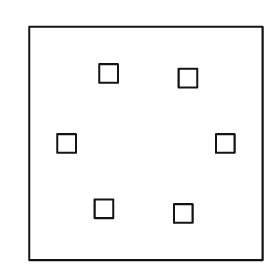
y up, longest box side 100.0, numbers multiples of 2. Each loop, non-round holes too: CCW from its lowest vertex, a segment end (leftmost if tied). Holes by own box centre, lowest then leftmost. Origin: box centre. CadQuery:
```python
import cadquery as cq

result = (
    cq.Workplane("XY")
    .moveTo(-50.0, -50.0)
    .lineTo(50.0, -50.0)
    .lineTo(50.0, 50.0)
    .lineTo(-50.0, 50.0)
    .close()
    .moveTo(12.0, -34.0)
    .lineTo(20.0, -34.0)
    .lineTo(20.0, -26.0)
    .lineTo(12.0, -26.0)
    .close()
    .moveTo(-22.0, -32.0)
    .lineTo(-14.0, -32.0)
    .lineTo(-14.0, -24.0)
    .lineTo(-22.0, -24.0)
    .close()
    .moveTo(-38.0, -4.0)
    .lineTo(-30.0, -4.0)
    .lineTo(-30.0, 4.0)
    .lineTo(-38.0, 4.0)
    .close()
    .moveTo(30.0, -4.0)
    .lineTo(38.0, -4.0)
    .lineTo(38.0, 4.0)
    .lineTo(30.0, 4.0)
    .close()
    .moveTo(14.0, 24.0)
    .lineTo(22.0, 24.0)
    .lineTo(22.0, 32.0)
    .lineTo(14.0, 32.0)
    .close()
    .moveTo(-20.0, 26.0)
    .lineTo(-12.0, 26.0)
    .lineTo(-12.0, 34.0)
    .lineTo(-20.0, 34.0)
    .close()
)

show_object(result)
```